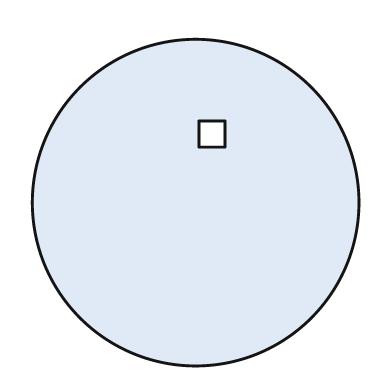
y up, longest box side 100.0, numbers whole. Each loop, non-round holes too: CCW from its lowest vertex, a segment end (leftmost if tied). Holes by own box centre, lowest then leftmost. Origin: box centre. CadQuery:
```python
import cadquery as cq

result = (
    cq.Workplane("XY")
    .moveTo(0.0, 0.0)
    .circle(50.0)
    .moveTo(1.0, 17.0)
    .lineTo(9.0, 17.0)
    .lineTo(9.0, 25.0)
    .lineTo(1.0, 25.0)
    .close()
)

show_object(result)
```